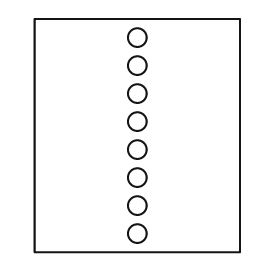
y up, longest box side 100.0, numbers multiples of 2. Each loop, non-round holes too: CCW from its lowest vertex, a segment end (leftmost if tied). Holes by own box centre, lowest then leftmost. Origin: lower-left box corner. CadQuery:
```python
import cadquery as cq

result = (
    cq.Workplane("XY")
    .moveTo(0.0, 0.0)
    .lineTo(88.0, 0.0)
    .lineTo(88.0, 100.0)
    .lineTo(0.0, 100.0)
    .close()
    .moveTo(44.0, 8.0)
    .circle(4.0)
    .moveTo(44.0, 20.0)
    .circle(4.0)
    .moveTo(44.0, 32.0)
    .circle(4.0)
    .moveTo(44.0, 44.0)
    .circle(4.0)
    .moveTo(44.0, 56.0)
    .circle(4.0)
    .moveTo(44.0, 68.0)
    .circle(4.0)
    .moveTo(44.0, 80.0)
    .circle(4.0)
    .moveTo(44.0, 92.0)
    .circle(4.0)
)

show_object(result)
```